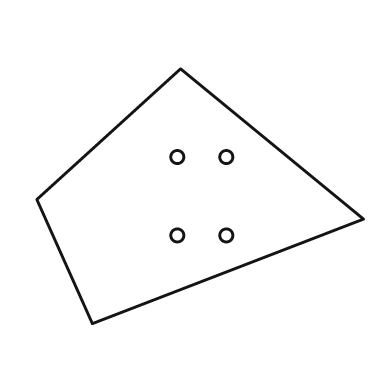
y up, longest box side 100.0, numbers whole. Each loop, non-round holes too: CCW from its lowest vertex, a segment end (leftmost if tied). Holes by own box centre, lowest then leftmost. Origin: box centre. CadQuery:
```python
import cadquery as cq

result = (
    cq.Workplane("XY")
    .moveTo(-33.0, -39.0)
    .lineTo(50.0, -7.0)
    .lineTo(-6.0, 39.0)
    .lineTo(-50.0, -1.0)
    .close()
    .moveTo(-7.0, -12.0)
    .circle(2.0)
    .moveTo(8.0, -12.0)
    .circle(2.0)
    .moveTo(-7.0, 12.0)
    .circle(2.0)
    .moveTo(8.0, 12.0)
    .circle(2.0)
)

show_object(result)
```